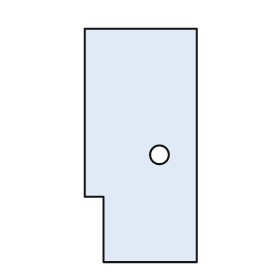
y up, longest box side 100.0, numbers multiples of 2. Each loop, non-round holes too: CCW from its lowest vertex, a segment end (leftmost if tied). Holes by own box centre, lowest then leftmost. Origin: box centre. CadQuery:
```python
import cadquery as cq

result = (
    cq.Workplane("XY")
    .moveTo(-16.0, -50.0)
    .lineTo(24.0, -50.0)
    .lineTo(24.0, 50.0)
    .lineTo(-24.0, 50.0)
    .lineTo(-24.0, -22.0)
    .lineTo(-16.0, -22.0)
    .close()
    .moveTo(8.0, -4.0)
    .circle(4.0)
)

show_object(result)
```